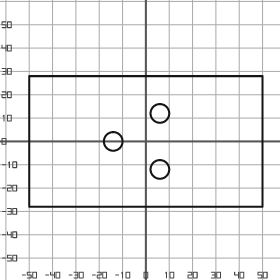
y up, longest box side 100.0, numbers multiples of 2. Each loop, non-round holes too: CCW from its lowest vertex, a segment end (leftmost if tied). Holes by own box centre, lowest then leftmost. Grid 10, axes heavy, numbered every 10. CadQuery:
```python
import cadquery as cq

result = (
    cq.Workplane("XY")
    .moveTo(-50.0, -28.0)
    .lineTo(50.0, -28.0)
    .lineTo(50.0, 28.0)
    .lineTo(-50.0, 28.0)
    .close()
    .moveTo(6.0, -12.0)
    .circle(4.0)
    .moveTo(-14.0, 0.0)
    .circle(4.0)
    .moveTo(6.0, 12.0)
    .circle(4.0)
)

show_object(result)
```